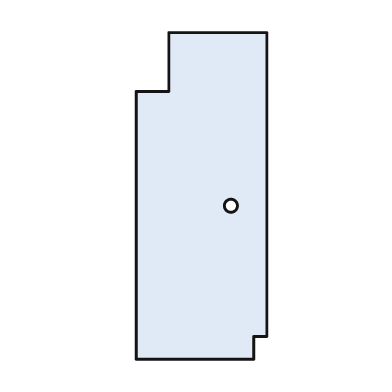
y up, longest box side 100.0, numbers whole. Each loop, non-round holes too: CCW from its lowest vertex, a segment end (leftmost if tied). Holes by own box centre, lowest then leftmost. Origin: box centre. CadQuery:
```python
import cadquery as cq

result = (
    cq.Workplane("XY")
    .moveTo(-20.0, -50.0)
    .lineTo(16.0, -50.0)
    .lineTo(16.0, -43.0)
    .lineTo(20.0, -43.0)
    .lineTo(20.0, 50.0)
    .lineTo(-10.0, 50.0)
    .lineTo(-10.0, 32.0)
    .lineTo(-20.0, 32.0)
    .close()
    .moveTo(9.0, -3.0)
    .circle(2.0)
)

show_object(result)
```